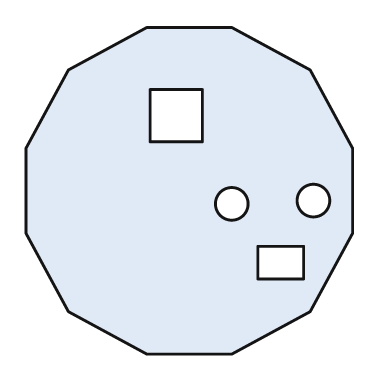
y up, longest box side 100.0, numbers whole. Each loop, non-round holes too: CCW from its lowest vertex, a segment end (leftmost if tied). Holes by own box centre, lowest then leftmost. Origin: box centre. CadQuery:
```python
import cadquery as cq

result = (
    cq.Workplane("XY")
    .moveTo(-13.0, -50.0)
    .lineTo(13.0, -50.0)
    .lineTo(37.0, -37.0)
    .lineTo(50.0, -13.0)
    .lineTo(50.0, 13.0)
    .lineTo(37.0, 37.0)
    .lineTo(13.0, 50.0)
    .lineTo(-13.0, 50.0)
    .lineTo(-37.0, 37.0)
    .lineTo(-50.0, 13.0)
    .lineTo(-50.0, -13.0)
    .lineTo(-37.0, -37.0)
    .close()
    .moveTo(21.0, -27.0)
    .lineTo(35.0, -27.0)
    .lineTo(35.0, -17.0)
    .lineTo(21.0, -17.0)
    .close()
    .moveTo(13.0, -4.0)
    .circle(5.0)
    .moveTo(38.0, -3.0)
    .circle(5.0)
    .moveTo(-12.0, 15.0)
    .lineTo(4.0, 15.0)
    .lineTo(4.0, 31.0)
    .lineTo(-12.0, 31.0)
    .close()
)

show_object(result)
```